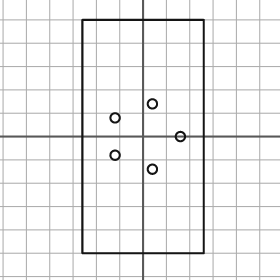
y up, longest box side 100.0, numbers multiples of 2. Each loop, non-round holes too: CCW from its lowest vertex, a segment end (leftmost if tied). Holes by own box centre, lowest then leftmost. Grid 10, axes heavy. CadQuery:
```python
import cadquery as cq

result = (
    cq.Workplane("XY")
    .moveTo(-26.0, -50.0)
    .lineTo(26.0, -50.0)
    .lineTo(26.0, 50.0)
    .lineTo(-26.0, 50.0)
    .close()
    .moveTo(4.0, -14.0)
    .circle(2.0)
    .moveTo(-12.0, -8.0)
    .circle(2.0)
    .moveTo(16.0, 0.0)
    .circle(2.0)
    .moveTo(-12.0, 8.0)
    .circle(2.0)
    .moveTo(4.0, 14.0)
    .circle(2.0)
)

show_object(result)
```